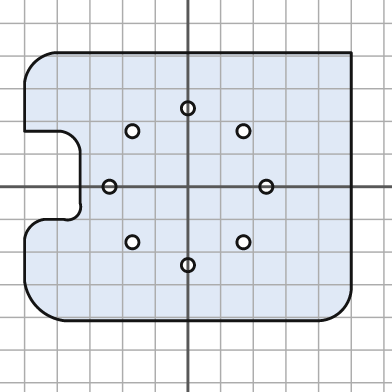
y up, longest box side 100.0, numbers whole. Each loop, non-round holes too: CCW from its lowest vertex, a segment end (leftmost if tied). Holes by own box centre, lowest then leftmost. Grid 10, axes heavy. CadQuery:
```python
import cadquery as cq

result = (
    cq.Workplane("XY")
    .moveTo(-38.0, -41.0)
    .lineTo(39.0, -41.0)
    .threePointArc((47.0, -38.0), (50.0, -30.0))
    .lineTo(50.0, 41.0)
    .lineTo(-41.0, 41.0)
    .threePointArc((-47.0, 38.0), (-50.0, 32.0))
    .lineTo(-50.0, 17.0)
    .lineTo(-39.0, 17.0)
    .threePointArc((-35.0, 15.0), (-33.0, 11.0))
    .lineTo(-33.0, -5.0)
    .threePointArc((-34.0, -9.0), (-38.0, -10.0))
    .lineTo(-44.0, -10.0)
    .threePointArc((-48.0, -12.0), (-50.0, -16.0))
    .lineTo(-50.0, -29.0)
    .threePointArc((-46.0, -37.0), (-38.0, -41.0))
    .close()
    .moveTo(0.0, -24.0)
    .circle(2.0)
    .moveTo(-17.0, -17.0)
    .circle(2.0)
    .moveTo(17.0, -17.0)
    .circle(2.0)
    .moveTo(-24.0, 0.0)
    .circle(2.0)
    .moveTo(24.0, 0.0)
    .circle(2.0)
    .moveTo(-17.0, 17.0)
    .circle(2.0)
    .moveTo(17.0, 17.0)
    .circle(2.0)
    .moveTo(0.0, 24.0)
    .circle(2.0)
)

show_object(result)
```